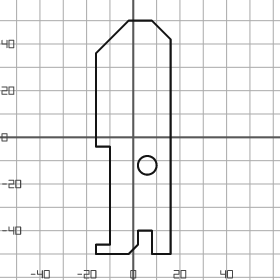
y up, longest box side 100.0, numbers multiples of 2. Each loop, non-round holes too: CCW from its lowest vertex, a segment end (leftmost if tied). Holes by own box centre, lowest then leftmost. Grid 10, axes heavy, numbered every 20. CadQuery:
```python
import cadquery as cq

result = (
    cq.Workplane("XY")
    .moveTo(-16.0, -50.0)
    .lineTo(-2.0, -50.0)
    .lineTo(2.0, -46.0)
    .lineTo(2.0, -40.0)
    .lineTo(8.0, -40.0)
    .lineTo(8.0, -50.0)
    .lineTo(16.0, -50.0)
    .lineTo(16.0, 42.0)
    .lineTo(8.0, 50.0)
    .lineTo(-2.0, 50.0)
    .lineTo(-16.0, 36.0)
    .lineTo(-16.0, -4.0)
    .lineTo(-10.0, -4.0)
    .lineTo(-10.0, -46.0)
    .lineTo(-16.0, -46.0)
    .close()
    .moveTo(6.0, -12.0)
    .circle(4.0)
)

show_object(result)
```